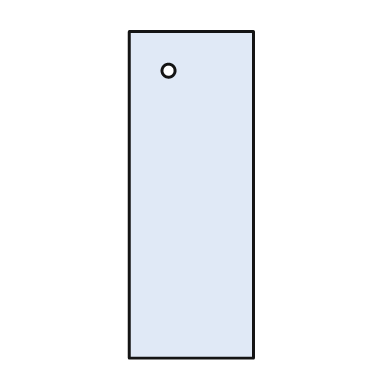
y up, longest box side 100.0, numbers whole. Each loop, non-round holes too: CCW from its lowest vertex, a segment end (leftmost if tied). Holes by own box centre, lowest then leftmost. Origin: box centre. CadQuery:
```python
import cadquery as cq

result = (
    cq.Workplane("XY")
    .moveTo(-19.0, -50.0)
    .lineTo(19.0, -50.0)
    .lineTo(19.0, 50.0)
    .lineTo(-19.0, 50.0)
    .close()
    .moveTo(-7.0, 38.0)
    .circle(2.0)
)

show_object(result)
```